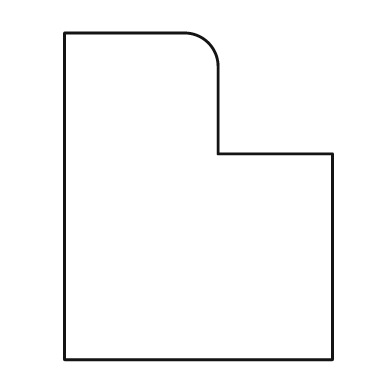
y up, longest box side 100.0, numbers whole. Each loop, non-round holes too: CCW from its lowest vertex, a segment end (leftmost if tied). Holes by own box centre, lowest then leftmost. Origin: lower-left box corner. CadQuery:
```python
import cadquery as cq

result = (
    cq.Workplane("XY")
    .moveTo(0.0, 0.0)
    .lineTo(82.0, 0.0)
    .lineTo(82.0, 63.0)
    .lineTo(47.0, 63.0)
    .lineTo(47.0, 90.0)
    .threePointArc((44.0, 97.0), (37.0, 100.0))
    .lineTo(0.0, 100.0)
    .close()
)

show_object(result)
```